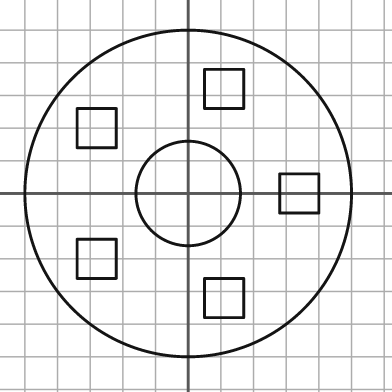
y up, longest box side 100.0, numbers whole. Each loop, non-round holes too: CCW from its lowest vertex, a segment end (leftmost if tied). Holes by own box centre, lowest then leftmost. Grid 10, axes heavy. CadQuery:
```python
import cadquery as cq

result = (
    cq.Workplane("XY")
    .moveTo(0.0, 0.0)
    .circle(50.0)
    .moveTo(5.0, -38.0)
    .lineTo(17.0, -38.0)
    .lineTo(17.0, -26.0)
    .lineTo(5.0, -26.0)
    .close()
    .moveTo(-34.0, -26.0)
    .lineTo(-22.0, -26.0)
    .lineTo(-22.0, -14.0)
    .lineTo(-34.0, -14.0)
    .close()
    .moveTo(0.0, 0.0)
    .circle(16.0)
    .moveTo(28.0, -6.0)
    .lineTo(40.0, -6.0)
    .lineTo(40.0, 6.0)
    .lineTo(28.0, 6.0)
    .close()
    .moveTo(-34.0, 14.0)
    .lineTo(-22.0, 14.0)
    .lineTo(-22.0, 26.0)
    .lineTo(-34.0, 26.0)
    .close()
    .moveTo(5.0, 26.0)
    .lineTo(17.0, 26.0)
    .lineTo(17.0, 38.0)
    .lineTo(5.0, 38.0)
    .close()
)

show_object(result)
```